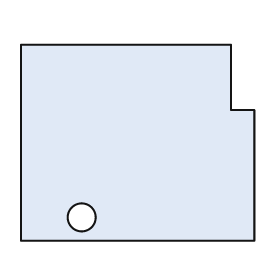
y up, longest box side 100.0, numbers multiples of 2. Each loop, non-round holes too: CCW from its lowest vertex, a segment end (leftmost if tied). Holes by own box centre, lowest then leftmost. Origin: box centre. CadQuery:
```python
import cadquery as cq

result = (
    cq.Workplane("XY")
    .moveTo(-50.0, -42.0)
    .lineTo(50.0, -42.0)
    .lineTo(50.0, 14.0)
    .lineTo(40.0, 14.0)
    .lineTo(40.0, 42.0)
    .lineTo(-50.0, 42.0)
    .close()
    .moveTo(-24.0, -32.0)
    .circle(6.0)
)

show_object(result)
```